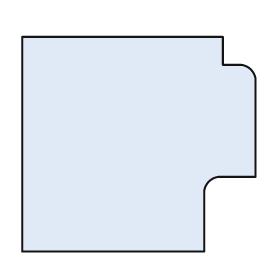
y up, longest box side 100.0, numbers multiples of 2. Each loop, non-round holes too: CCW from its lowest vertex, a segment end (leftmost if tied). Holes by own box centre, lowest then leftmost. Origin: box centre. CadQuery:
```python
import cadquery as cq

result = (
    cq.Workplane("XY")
    .moveTo(-50.0, -46.0)
    .lineTo(28.0, -46.0)
    .lineTo(28.0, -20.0)
    .threePointArc((30.0, -16.0), (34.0, -14.0))
    .lineTo(50.0, -14.0)
    .lineTo(50.0, 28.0)
    .threePointArc((48.0, 32.0), (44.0, 34.0))
    .lineTo(36.0, 34.0)
    .lineTo(36.0, 46.0)
    .lineTo(-50.0, 46.0)
    .close()
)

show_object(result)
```